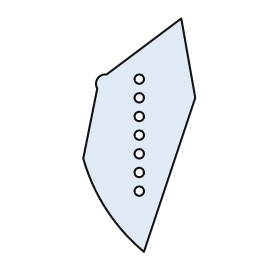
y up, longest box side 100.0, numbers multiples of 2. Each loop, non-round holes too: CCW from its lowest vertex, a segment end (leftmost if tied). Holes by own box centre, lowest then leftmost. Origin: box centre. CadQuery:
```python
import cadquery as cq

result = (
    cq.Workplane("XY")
    .moveTo(2.0, -50.0)
    .lineTo(24.0, 16.0)
    .lineTo(18.0, 50.0)
    .lineTo(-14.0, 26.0)
    .threePointArc((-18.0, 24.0), (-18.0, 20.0))
    .lineTo(-24.0, -10.0)
    .threePointArc((-14.0, -32.0), (2.0, -50.0))
    .close()
    .moveTo(0.0, -24.0)
    .circle(2.0)
    .moveTo(0.0, -16.0)
    .circle(2.0)
    .moveTo(0.0, -8.0)
    .circle(2.0)
    .moveTo(0.0, 0.0)
    .circle(2.0)
    .moveTo(0.0, 8.0)
    .circle(2.0)
    .moveTo(0.0, 16.0)
    .circle(2.0)
    .moveTo(0.0, 24.0)
    .circle(2.0)
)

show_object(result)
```